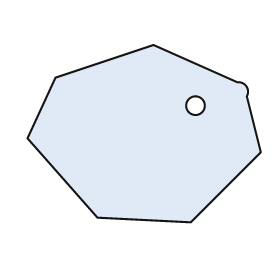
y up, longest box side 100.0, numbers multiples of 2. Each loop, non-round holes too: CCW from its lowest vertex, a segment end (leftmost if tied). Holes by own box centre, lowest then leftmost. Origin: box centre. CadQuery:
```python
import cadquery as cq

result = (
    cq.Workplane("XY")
    .moveTo(20.0, -38.0)
    .lineTo(50.0, -8.0)
    .lineTo(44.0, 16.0)
    .threePointArc((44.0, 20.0), (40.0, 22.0))
    .lineTo(4.0, 38.0)
    .lineTo(-38.0, 24.0)
    .lineTo(-50.0, -2.0)
    .lineTo(-20.0, -36.0)
    .close()
    .moveTo(22.0, 12.0)
    .circle(4.0)
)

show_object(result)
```